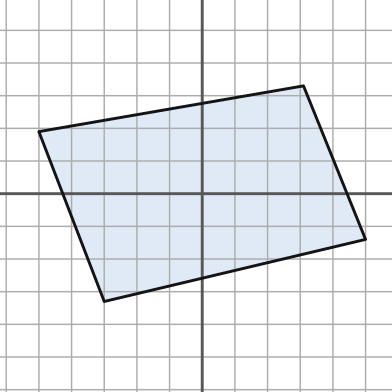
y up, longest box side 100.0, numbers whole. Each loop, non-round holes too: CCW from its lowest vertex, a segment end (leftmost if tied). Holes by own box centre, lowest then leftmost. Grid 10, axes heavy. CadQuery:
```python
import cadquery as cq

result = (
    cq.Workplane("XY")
    .moveTo(-30.0, -33.0)
    .lineTo(50.0, -14.0)
    .lineTo(31.0, 33.0)
    .lineTo(-50.0, 19.0)
    .close()
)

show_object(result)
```